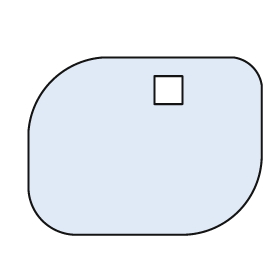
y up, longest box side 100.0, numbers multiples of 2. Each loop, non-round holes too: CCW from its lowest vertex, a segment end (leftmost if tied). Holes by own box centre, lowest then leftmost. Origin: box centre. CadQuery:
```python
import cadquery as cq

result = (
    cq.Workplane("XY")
    .moveTo(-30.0, -38.0)
    .lineTo(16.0, -38.0)
    .threePointArc((40.0, -28.0), (50.0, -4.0))
    .lineTo(50.0, 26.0)
    .threePointArc((46.0, 34.0), (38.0, 38.0))
    .lineTo(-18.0, 38.0)
    .threePointArc((-40.0, 28.0), (-50.0, 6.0))
    .lineTo(-50.0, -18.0)
    .threePointArc((-44.0, -32.0), (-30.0, -38.0))
    .close()
    .moveTo(4.0, 18.0)
    .lineTo(16.0, 18.0)
    .lineTo(16.0, 30.0)
    .lineTo(4.0, 30.0)
    .close()
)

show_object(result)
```